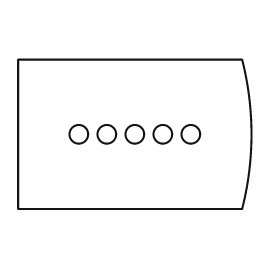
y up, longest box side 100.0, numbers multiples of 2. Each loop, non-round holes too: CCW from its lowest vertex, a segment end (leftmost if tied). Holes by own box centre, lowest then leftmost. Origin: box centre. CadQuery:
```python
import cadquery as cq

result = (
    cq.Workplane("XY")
    .moveTo(-50.0, -32.0)
    .lineTo(46.0, -32.0)
    .threePointArc((50.0, 0.0), (46.0, 32.0))
    .lineTo(-50.0, 32.0)
    .close()
    .moveTo(-24.0, 0.0)
    .circle(4.0)
    .moveTo(-12.0, 0.0)
    .circle(4.0)
    .moveTo(0.0, 0.0)
    .circle(4.0)
    .moveTo(12.0, 0.0)
    .circle(4.0)
    .moveTo(24.0, 0.0)
    .circle(4.0)
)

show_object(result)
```